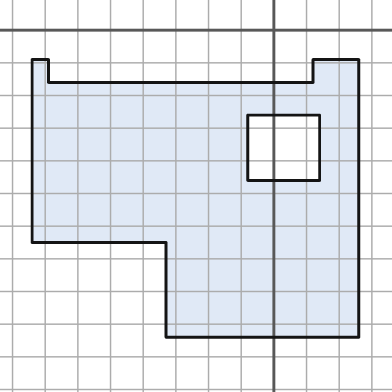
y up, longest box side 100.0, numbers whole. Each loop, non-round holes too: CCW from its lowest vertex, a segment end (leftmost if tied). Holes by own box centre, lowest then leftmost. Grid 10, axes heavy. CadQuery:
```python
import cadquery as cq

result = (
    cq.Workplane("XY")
    .moveTo(-33.0, -94.0)
    .lineTo(26.0, -94.0)
    .lineTo(26.0, -9.0)
    .lineTo(12.0, -9.0)
    .lineTo(12.0, -16.0)
    .lineTo(-69.0, -16.0)
    .lineTo(-69.0, -9.0)
    .lineTo(-74.0, -9.0)
    .lineTo(-74.0, -65.0)
    .lineTo(-33.0, -65.0)
    .close()
    .moveTo(-8.0, -46.0)
    .lineTo(14.0, -46.0)
    .lineTo(14.0, -26.0)
    .lineTo(-8.0, -26.0)
    .close()
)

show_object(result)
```